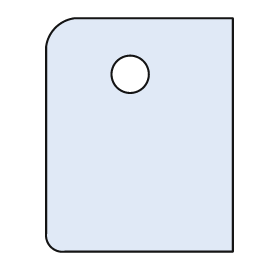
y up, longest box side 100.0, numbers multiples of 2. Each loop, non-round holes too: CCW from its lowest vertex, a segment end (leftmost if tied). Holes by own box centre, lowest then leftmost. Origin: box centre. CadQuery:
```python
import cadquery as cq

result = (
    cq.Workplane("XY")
    .moveTo(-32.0, -50.0)
    .lineTo(40.0, -50.0)
    .lineTo(40.0, 50.0)
    .lineTo(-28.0, 50.0)
    .threePointArc((-36.0, 46.0), (-40.0, 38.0))
    .lineTo(-40.0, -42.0)
    .threePointArc((-38.0, -48.0), (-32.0, -50.0))
    .close()
    .moveTo(-4.0, 26.0)
    .circle(8.0)
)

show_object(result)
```